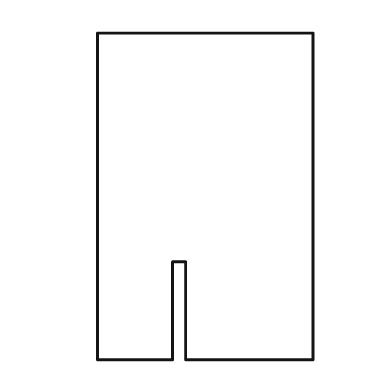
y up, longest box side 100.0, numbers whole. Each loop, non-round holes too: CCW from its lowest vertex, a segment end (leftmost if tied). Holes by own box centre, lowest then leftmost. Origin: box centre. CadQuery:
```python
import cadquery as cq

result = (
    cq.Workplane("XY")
    .moveTo(-33.0, -50.0)
    .lineTo(-10.0, -50.0)
    .lineTo(-10.0, -20.0)
    .lineTo(-6.0, -20.0)
    .lineTo(-6.0, -50.0)
    .lineTo(33.0, -50.0)
    .lineTo(33.0, 50.0)
    .lineTo(-33.0, 50.0)
    .close()
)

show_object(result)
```